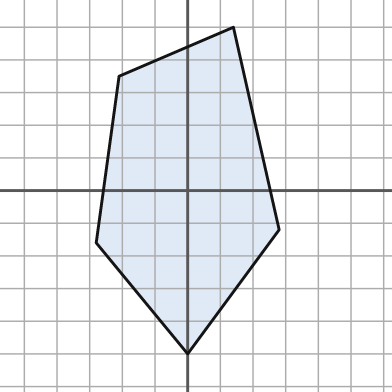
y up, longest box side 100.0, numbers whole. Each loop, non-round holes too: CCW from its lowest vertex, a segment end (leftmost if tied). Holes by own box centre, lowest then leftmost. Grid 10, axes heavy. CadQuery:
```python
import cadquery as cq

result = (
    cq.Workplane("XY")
    .moveTo(0.0, -50.0)
    .lineTo(28.0, -12.0)
    .lineTo(14.0, 50.0)
    .lineTo(-21.0, 35.0)
    .lineTo(-28.0, -16.0)
    .close()
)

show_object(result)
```